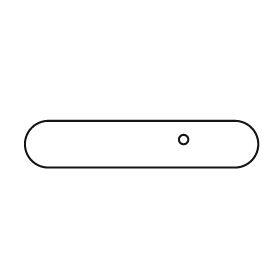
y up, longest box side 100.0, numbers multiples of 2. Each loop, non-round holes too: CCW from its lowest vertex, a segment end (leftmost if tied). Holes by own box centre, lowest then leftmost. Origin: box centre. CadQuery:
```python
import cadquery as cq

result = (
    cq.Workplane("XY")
    .moveTo(-40.0, -10.0)
    .lineTo(40.0, -10.0)
    .threePointArc((50.0, 0.0), (40.0, 10.0))
    .lineTo(-40.0, 10.0)
    .threePointArc((-50.0, 0.0), (-40.0, -10.0))
    .close()
    .moveTo(18.0, 2.0)
    .circle(2.0)
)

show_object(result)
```